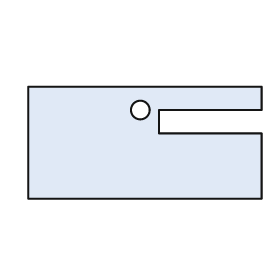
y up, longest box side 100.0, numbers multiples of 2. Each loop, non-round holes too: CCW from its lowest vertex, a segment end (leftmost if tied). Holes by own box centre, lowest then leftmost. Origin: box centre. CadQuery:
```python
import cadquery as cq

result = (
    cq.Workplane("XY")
    .moveTo(-50.0, -24.0)
    .lineTo(50.0, -24.0)
    .lineTo(50.0, 4.0)
    .lineTo(6.0, 4.0)
    .lineTo(6.0, 14.0)
    .lineTo(50.0, 14.0)
    .lineTo(50.0, 24.0)
    .lineTo(-50.0, 24.0)
    .close()
    .moveTo(-2.0, 14.0)
    .circle(4.0)
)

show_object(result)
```